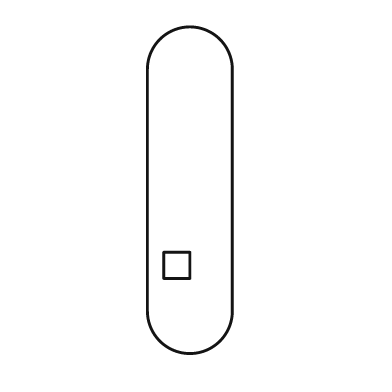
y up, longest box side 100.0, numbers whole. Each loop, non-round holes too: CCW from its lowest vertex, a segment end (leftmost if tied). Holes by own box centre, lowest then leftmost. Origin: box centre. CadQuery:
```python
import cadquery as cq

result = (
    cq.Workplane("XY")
    .moveTo(-13.0, -37.0)
    .threePointArc((0.0, -50.0), (13.0, -37.0))
    .lineTo(13.0, 37.0)
    .threePointArc((0.0, 50.0), (-13.0, 37.0))
    .close()
    .moveTo(-8.0, -27.0)
    .lineTo(0.0, -27.0)
    .lineTo(0.0, -19.0)
    .lineTo(-8.0, -19.0)
    .close()
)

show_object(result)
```